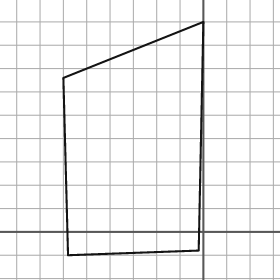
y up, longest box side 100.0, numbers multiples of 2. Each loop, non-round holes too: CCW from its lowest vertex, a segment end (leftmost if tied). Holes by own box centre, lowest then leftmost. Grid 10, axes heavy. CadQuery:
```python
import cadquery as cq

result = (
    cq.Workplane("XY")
    .moveTo(-58.0, -10.0)
    .lineTo(-2.0, -8.0)
    .lineTo(0.0, 90.0)
    .lineTo(-60.0, 66.0)
    .close()
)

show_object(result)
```